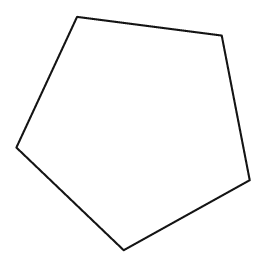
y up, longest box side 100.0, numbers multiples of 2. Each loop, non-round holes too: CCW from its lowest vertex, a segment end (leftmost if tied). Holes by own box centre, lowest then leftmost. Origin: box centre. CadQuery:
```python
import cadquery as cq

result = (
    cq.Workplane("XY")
    .moveTo(-4.0, -50.0)
    .lineTo(50.0, -20.0)
    .lineTo(38.0, 42.0)
    .lineTo(-24.0, 50.0)
    .lineTo(-50.0, -6.0)
    .close()
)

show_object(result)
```